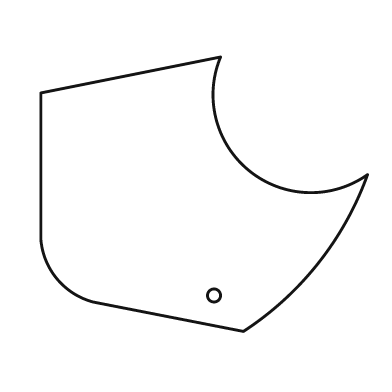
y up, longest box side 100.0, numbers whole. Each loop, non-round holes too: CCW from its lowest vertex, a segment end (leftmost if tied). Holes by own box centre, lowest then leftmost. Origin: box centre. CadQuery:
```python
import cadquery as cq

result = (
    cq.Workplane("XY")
    .moveTo(12.0, -42.0)
    .threePointArc((35.0, -21.0), (50.0, 6.0))
    .threePointArc((14.0, 7.0), (5.0, 42.0))
    .lineTo(-50.0, 31.0)
    .lineTo(-50.0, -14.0)
    .threePointArc((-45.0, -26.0), (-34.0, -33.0))
    .close()
    .moveTo(3.0, -31.0)
    .circle(2.0)
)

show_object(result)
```